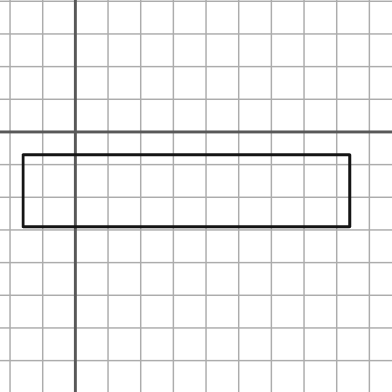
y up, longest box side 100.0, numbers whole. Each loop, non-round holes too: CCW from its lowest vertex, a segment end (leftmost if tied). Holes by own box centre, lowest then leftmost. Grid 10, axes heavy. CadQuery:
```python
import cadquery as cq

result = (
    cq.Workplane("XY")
    .moveTo(-16.0, -29.0)
    .lineTo(84.0, -29.0)
    .lineTo(84.0, -7.0)
    .lineTo(-16.0, -7.0)
    .close()
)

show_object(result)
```